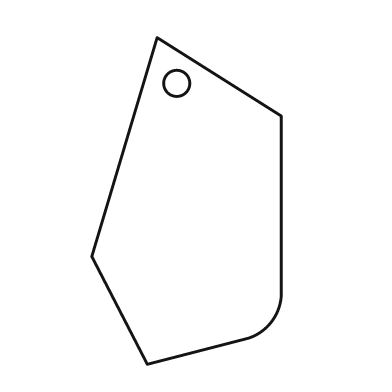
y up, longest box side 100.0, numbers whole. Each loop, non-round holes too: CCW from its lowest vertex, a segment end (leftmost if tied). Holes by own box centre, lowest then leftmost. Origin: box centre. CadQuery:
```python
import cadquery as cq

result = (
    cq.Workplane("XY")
    .moveTo(-12.0, -50.0)
    .lineTo(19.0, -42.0)
    .threePointArc((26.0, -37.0), (29.0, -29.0))
    .lineTo(29.0, 26.0)
    .lineTo(-9.0, 50.0)
    .lineTo(-29.0, -17.0)
    .close()
    .moveTo(-3.0, 36.0)
    .circle(4.0)
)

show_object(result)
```